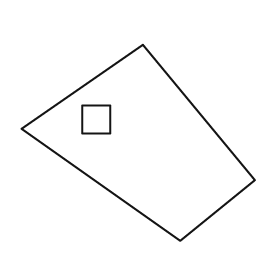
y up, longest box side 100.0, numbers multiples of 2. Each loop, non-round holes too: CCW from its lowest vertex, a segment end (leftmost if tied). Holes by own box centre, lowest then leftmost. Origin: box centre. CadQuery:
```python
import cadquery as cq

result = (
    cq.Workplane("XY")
    .moveTo(18.0, -42.0)
    .lineTo(50.0, -16.0)
    .lineTo(2.0, 42.0)
    .lineTo(-50.0, 6.0)
    .close()
    .moveTo(-24.0, 4.0)
    .lineTo(-12.0, 4.0)
    .lineTo(-12.0, 16.0)
    .lineTo(-24.0, 16.0)
    .close()
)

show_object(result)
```